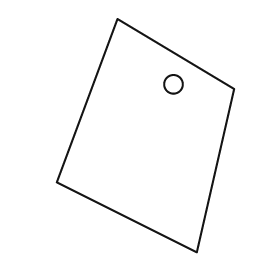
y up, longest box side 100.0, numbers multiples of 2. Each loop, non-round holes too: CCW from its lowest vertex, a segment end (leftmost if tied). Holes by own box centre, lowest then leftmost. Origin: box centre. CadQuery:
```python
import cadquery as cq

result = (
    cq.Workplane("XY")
    .moveTo(22.0, -50.0)
    .lineTo(38.0, 20.0)
    .lineTo(-12.0, 50.0)
    .lineTo(-38.0, -20.0)
    .close()
    .moveTo(12.0, 22.0)
    .circle(4.0)
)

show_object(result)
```